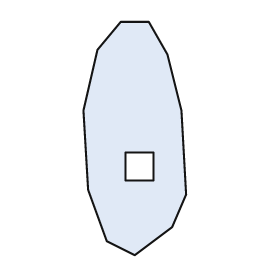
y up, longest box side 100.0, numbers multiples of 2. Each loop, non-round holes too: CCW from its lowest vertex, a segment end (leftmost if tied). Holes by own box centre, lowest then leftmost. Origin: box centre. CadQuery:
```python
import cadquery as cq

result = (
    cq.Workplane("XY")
    .moveTo(0.0, -50.0)
    .lineTo(16.0, -38.0)
    .lineTo(22.0, -24.0)
    .lineTo(20.0, 12.0)
    .lineTo(14.0, 36.0)
    .lineTo(6.0, 50.0)
    .lineTo(-6.0, 50.0)
    .lineTo(-16.0, 38.0)
    .lineTo(-22.0, 12.0)
    .lineTo(-20.0, -22.0)
    .lineTo(-12.0, -44.0)
    .close()
    .moveTo(-4.0, -18.0)
    .lineTo(8.0, -18.0)
    .lineTo(8.0, -6.0)
    .lineTo(-4.0, -6.0)
    .close()
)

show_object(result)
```